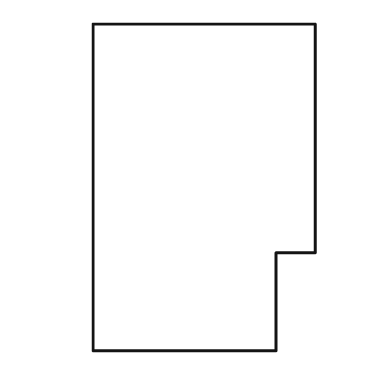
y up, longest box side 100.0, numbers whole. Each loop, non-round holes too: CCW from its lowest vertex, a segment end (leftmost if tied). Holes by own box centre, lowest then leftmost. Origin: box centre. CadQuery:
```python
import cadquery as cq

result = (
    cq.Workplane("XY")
    .moveTo(-34.0, -50.0)
    .lineTo(22.0, -50.0)
    .lineTo(22.0, -20.0)
    .lineTo(34.0, -20.0)
    .lineTo(34.0, 50.0)
    .lineTo(-34.0, 50.0)
    .close()
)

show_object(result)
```